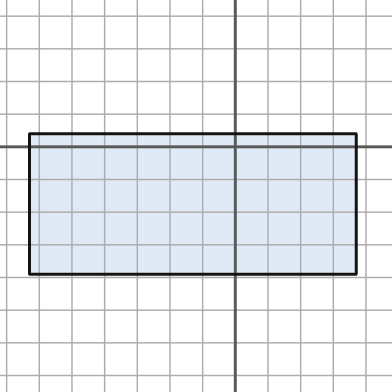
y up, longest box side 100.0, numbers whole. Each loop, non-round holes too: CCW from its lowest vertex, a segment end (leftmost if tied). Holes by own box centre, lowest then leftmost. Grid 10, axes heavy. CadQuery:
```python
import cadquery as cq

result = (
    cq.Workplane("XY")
    .moveTo(-63.0, -39.0)
    .lineTo(37.0, -39.0)
    .lineTo(37.0, 4.0)
    .lineTo(-63.0, 4.0)
    .close()
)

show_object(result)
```